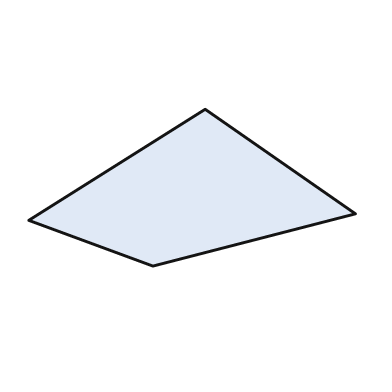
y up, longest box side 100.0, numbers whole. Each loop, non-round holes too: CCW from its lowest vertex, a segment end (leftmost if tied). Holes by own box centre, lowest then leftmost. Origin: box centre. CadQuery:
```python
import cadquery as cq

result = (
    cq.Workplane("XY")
    .moveTo(-12.0, -24.0)
    .lineTo(50.0, -8.0)
    .lineTo(4.0, 24.0)
    .lineTo(-50.0, -10.0)
    .close()
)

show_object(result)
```